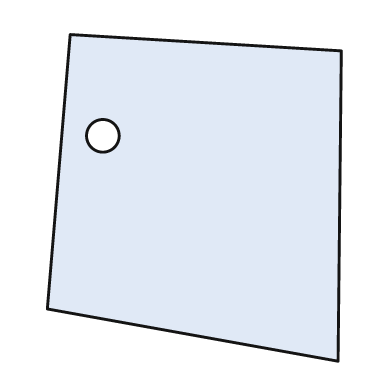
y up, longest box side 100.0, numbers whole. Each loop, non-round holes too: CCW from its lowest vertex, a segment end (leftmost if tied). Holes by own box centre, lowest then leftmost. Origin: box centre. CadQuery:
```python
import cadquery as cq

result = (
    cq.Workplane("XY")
    .moveTo(44.0, -50.0)
    .lineTo(45.0, 45.0)
    .lineTo(-38.0, 50.0)
    .lineTo(-45.0, -34.0)
    .close()
    .moveTo(-28.0, 19.0)
    .circle(5.0)
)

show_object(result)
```